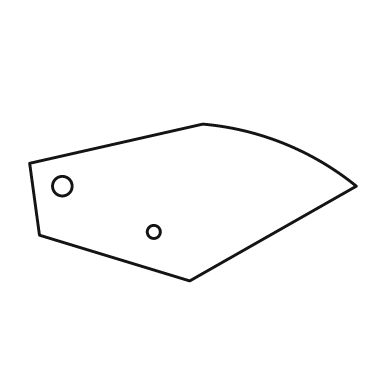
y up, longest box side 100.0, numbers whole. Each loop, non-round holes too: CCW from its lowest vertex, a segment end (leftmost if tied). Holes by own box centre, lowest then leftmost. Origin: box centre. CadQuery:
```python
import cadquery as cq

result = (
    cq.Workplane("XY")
    .moveTo(-1.0, -24.0)
    .lineTo(50.0, 5.0)
    .threePointArc((28.0, 18.0), (3.0, 24.0))
    .lineTo(-50.0, 12.0)
    .lineTo(-47.0, -10.0)
    .close()
    .moveTo(-12.0, -9.0)
    .circle(2.0)
    .moveTo(-40.0, 5.0)
    .circle(3.0)
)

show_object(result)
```